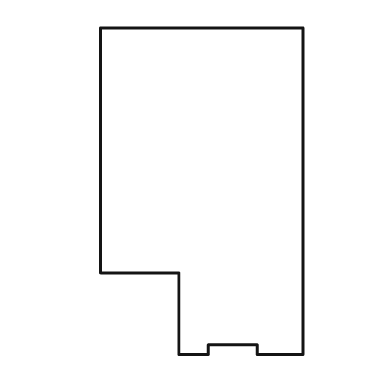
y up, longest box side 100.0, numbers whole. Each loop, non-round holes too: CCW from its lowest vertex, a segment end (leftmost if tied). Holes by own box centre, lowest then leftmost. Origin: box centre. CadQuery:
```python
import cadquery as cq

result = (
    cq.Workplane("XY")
    .moveTo(-7.0, -50.0)
    .lineTo(2.0, -50.0)
    .lineTo(2.0, -47.0)
    .lineTo(17.0, -47.0)
    .lineTo(17.0, -50.0)
    .lineTo(31.0, -50.0)
    .lineTo(31.0, 50.0)
    .lineTo(-31.0, 50.0)
    .lineTo(-31.0, -25.0)
    .lineTo(-7.0, -25.0)
    .close()
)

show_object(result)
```